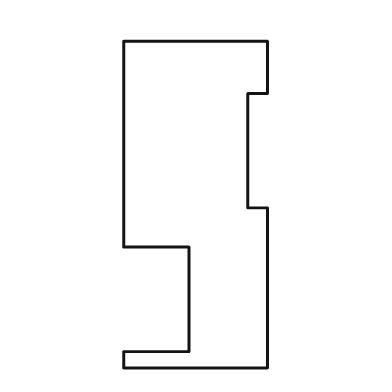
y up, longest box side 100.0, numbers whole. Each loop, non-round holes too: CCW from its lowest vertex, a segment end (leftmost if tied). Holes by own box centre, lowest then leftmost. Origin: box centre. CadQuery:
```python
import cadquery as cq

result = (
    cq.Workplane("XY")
    .moveTo(-22.0, -50.0)
    .lineTo(22.0, -50.0)
    .lineTo(22.0, -1.0)
    .lineTo(16.0, -1.0)
    .lineTo(16.0, 34.0)
    .lineTo(22.0, 34.0)
    .lineTo(22.0, 50.0)
    .lineTo(-22.0, 50.0)
    .lineTo(-22.0, -13.0)
    .lineTo(-2.0, -13.0)
    .lineTo(-2.0, -45.0)
    .lineTo(-22.0, -45.0)
    .close()
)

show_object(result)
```